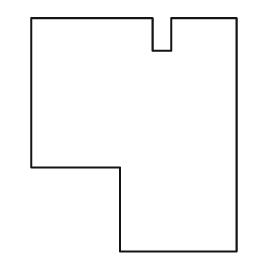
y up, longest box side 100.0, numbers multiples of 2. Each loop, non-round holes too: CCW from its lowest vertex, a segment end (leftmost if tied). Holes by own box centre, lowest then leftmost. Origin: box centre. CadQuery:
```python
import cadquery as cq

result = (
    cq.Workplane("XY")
    .moveTo(-6.0, -50.0)
    .lineTo(44.0, -50.0)
    .lineTo(44.0, 50.0)
    .lineTo(16.0, 50.0)
    .lineTo(16.0, 36.0)
    .lineTo(8.0, 36.0)
    .lineTo(8.0, 50.0)
    .lineTo(-44.0, 50.0)
    .lineTo(-44.0, -14.0)
    .lineTo(-6.0, -14.0)
    .close()
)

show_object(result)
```